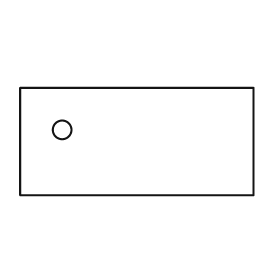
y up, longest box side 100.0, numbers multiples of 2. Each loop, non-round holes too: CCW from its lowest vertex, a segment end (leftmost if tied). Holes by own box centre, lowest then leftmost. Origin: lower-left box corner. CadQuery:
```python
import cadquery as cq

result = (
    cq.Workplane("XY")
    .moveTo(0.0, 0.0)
    .lineTo(100.0, 0.0)
    .lineTo(100.0, 46.0)
    .lineTo(0.0, 46.0)
    .close()
    .moveTo(18.0, 28.0)
    .circle(4.0)
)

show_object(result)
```